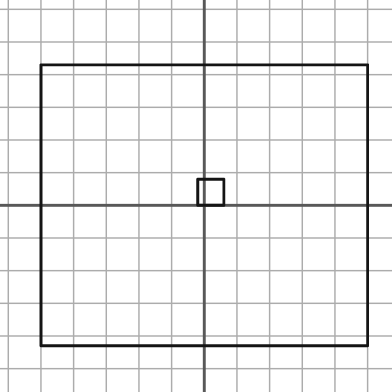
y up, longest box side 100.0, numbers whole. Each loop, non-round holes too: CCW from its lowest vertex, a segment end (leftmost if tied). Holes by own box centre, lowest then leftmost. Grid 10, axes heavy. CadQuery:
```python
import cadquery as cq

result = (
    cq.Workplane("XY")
    .moveTo(-50.0, -43.0)
    .lineTo(50.0, -43.0)
    .lineTo(50.0, 43.0)
    .lineTo(-50.0, 43.0)
    .close()
    .moveTo(-2.0, 0.0)
    .lineTo(6.0, 0.0)
    .lineTo(6.0, 8.0)
    .lineTo(-2.0, 8.0)
    .close()
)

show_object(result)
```